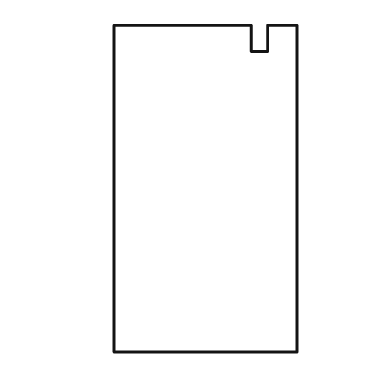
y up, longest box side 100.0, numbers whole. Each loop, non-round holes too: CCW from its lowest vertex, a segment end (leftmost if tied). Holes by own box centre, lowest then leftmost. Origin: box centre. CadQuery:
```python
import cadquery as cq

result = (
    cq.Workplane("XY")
    .moveTo(-28.0, -50.0)
    .lineTo(28.0, -50.0)
    .lineTo(28.0, 50.0)
    .lineTo(19.0, 50.0)
    .lineTo(19.0, 42.0)
    .lineTo(14.0, 42.0)
    .lineTo(14.0, 50.0)
    .lineTo(-28.0, 50.0)
    .close()
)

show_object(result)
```